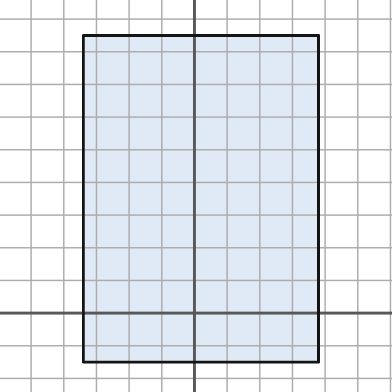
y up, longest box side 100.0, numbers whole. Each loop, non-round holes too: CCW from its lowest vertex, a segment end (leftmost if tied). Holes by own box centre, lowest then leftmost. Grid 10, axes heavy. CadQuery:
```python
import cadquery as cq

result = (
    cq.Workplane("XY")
    .moveTo(-34.0, -15.0)
    .lineTo(38.0, -15.0)
    .lineTo(38.0, 85.0)
    .lineTo(-34.0, 85.0)
    .close()
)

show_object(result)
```